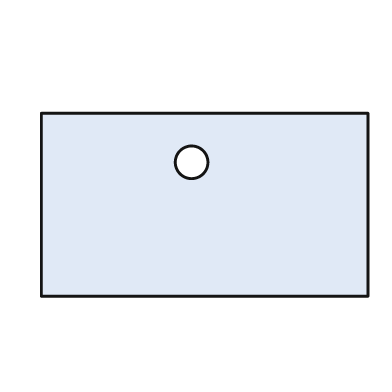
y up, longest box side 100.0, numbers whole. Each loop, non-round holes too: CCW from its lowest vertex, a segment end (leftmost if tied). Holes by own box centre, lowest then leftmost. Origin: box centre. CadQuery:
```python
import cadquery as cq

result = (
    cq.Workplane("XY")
    .moveTo(-50.0, -28.0)
    .lineTo(50.0, -28.0)
    .lineTo(50.0, 28.0)
    .lineTo(-50.0, 28.0)
    .close()
    .moveTo(-4.0, 13.0)
    .circle(5.0)
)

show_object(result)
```